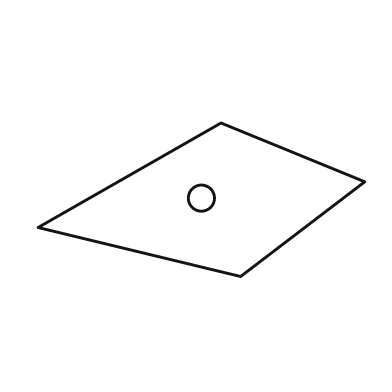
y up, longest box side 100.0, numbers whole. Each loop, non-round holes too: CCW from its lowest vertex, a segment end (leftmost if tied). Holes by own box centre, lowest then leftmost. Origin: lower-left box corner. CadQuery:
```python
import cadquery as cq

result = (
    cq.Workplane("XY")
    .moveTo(62.0, 0.0)
    .lineTo(100.0, 29.0)
    .lineTo(56.0, 47.0)
    .lineTo(0.0, 15.0)
    .close()
    .moveTo(50.0, 24.0)
    .circle(4.0)
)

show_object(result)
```